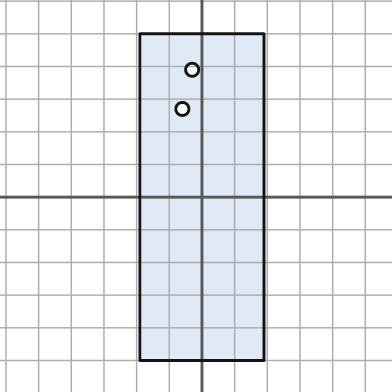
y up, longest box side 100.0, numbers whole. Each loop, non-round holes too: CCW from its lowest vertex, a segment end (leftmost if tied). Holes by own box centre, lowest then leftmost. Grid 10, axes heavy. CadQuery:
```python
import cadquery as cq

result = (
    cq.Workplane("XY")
    .moveTo(-19.0, -50.0)
    .lineTo(19.0, -50.0)
    .lineTo(19.0, 50.0)
    .lineTo(-19.0, 50.0)
    .close()
    .moveTo(-6.0, 27.0)
    .circle(2.0)
    .moveTo(-3.0, 39.0)
    .circle(2.0)
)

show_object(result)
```